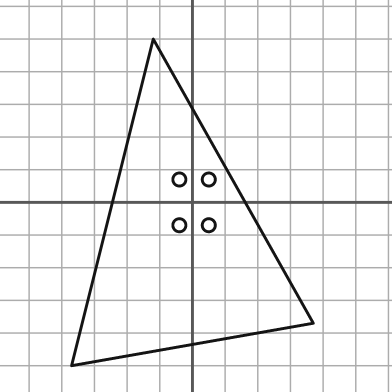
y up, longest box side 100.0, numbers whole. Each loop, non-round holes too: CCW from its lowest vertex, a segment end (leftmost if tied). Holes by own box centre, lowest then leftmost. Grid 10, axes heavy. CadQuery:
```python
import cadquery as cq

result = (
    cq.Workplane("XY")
    .moveTo(-37.0, -50.0)
    .lineTo(37.0, -37.0)
    .lineTo(-12.0, 50.0)
    .close()
    .moveTo(-4.0, -7.0)
    .circle(2.0)
    .moveTo(5.0, -7.0)
    .circle(2.0)
    .moveTo(-4.0, 7.0)
    .circle(2.0)
    .moveTo(5.0, 7.0)
    .circle(2.0)
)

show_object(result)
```